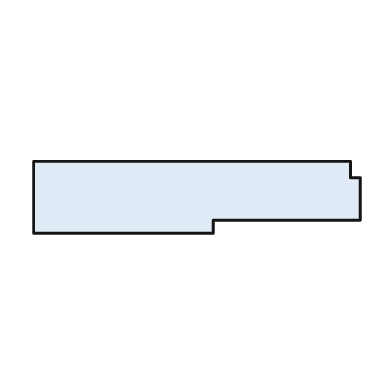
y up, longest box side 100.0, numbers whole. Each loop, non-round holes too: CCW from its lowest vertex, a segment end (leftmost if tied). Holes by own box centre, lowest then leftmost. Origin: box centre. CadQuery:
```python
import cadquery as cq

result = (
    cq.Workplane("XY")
    .moveTo(-50.0, -11.0)
    .lineTo(5.0, -11.0)
    .lineTo(5.0, -7.0)
    .lineTo(50.0, -7.0)
    .lineTo(50.0, 6.0)
    .lineTo(47.0, 6.0)
    .lineTo(47.0, 11.0)
    .lineTo(-50.0, 11.0)
    .close()
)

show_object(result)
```